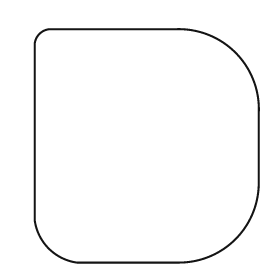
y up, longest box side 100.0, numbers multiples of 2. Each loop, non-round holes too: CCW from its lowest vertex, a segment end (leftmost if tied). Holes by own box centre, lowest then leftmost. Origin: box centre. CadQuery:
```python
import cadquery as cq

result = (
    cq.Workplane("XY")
    .moveTo(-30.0, -50.0)
    .lineTo(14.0, -50.0)
    .threePointArc((38.0, -40.0), (48.0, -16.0))
    .lineTo(48.0, 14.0)
    .threePointArc((38.0, 40.0), (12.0, 50.0))
    .lineTo(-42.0, 50.0)
    .threePointArc((-46.0, 48.0), (-48.0, 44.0))
    .lineTo(-48.0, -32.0)
    .threePointArc((-42.0, -44.0), (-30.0, -50.0))
    .close()
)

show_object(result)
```